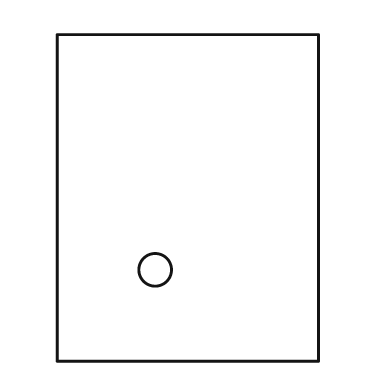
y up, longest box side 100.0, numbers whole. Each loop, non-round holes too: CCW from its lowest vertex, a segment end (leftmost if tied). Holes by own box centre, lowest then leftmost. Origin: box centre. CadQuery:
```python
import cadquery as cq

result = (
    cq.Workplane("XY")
    .moveTo(-40.0, -50.0)
    .lineTo(40.0, -50.0)
    .lineTo(40.0, 50.0)
    .lineTo(-40.0, 50.0)
    .close()
    .moveTo(-10.0, -22.0)
    .circle(5.0)
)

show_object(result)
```